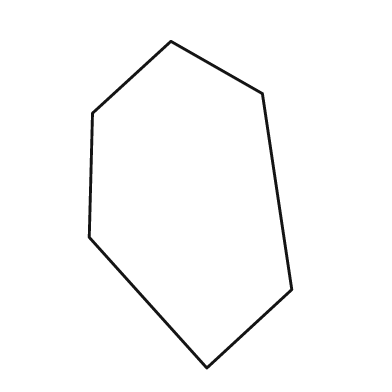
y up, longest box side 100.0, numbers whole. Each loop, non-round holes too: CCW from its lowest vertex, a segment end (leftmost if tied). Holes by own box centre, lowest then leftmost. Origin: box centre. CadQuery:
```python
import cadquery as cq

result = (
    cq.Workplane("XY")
    .moveTo(5.0, -50.0)
    .lineTo(31.0, -26.0)
    .lineTo(22.0, 34.0)
    .lineTo(-6.0, 50.0)
    .lineTo(-30.0, 28.0)
    .lineTo(-31.0, -10.0)
    .close()
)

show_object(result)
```